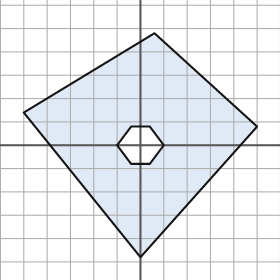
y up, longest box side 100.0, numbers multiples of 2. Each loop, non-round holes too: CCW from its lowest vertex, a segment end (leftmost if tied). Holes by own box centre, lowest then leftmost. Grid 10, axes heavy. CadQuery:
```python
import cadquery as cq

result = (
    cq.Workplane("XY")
    .moveTo(0.0, -48.0)
    .lineTo(50.0, 8.0)
    .lineTo(6.0, 48.0)
    .lineTo(-50.0, 14.0)
    .close()
    .moveTo(-4.0, -8.0)
    .lineTo(4.0, -8.0)
    .lineTo(10.0, 0.0)
    .lineTo(4.0, 8.0)
    .lineTo(-4.0, 8.0)
    .lineTo(-10.0, 0.0)
    .close()
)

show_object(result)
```